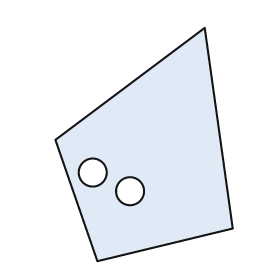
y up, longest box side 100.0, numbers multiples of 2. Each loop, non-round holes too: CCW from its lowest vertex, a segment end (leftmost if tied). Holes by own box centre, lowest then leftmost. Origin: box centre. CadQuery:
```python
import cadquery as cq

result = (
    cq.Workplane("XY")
    .moveTo(-20.0, -50.0)
    .lineTo(38.0, -36.0)
    .lineTo(26.0, 50.0)
    .lineTo(-38.0, 2.0)
    .close()
    .moveTo(-6.0, -20.0)
    .circle(6.0)
    .moveTo(-22.0, -12.0)
    .circle(6.0)
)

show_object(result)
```